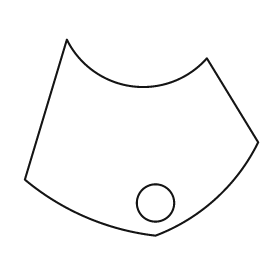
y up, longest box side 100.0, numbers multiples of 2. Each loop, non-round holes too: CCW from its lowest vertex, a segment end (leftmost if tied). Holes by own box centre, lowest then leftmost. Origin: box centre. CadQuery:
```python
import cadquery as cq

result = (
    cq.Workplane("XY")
    .moveTo(6.0, -42.0)
    .threePointArc((32.0, -26.0), (50.0, -2.0))
    .lineTo(28.0, 34.0)
    .threePointArc((-4.0, 22.0), (-32.0, 42.0))
    .lineTo(-50.0, -18.0)
    .threePointArc((-24.0, -34.0), (6.0, -42.0))
    .close()
    .moveTo(6.0, -28.0)
    .circle(8.0)
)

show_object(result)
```